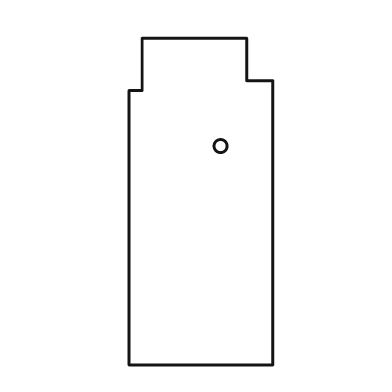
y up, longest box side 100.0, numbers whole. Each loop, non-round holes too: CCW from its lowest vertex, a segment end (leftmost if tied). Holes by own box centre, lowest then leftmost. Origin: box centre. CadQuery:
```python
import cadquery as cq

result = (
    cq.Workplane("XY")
    .moveTo(-22.0, -50.0)
    .lineTo(22.0, -50.0)
    .lineTo(22.0, 37.0)
    .lineTo(14.0, 37.0)
    .lineTo(14.0, 50.0)
    .lineTo(-18.0, 50.0)
    .lineTo(-18.0, 34.0)
    .lineTo(-22.0, 34.0)
    .close()
    .moveTo(6.0, 17.0)
    .circle(2.0)
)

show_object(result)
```